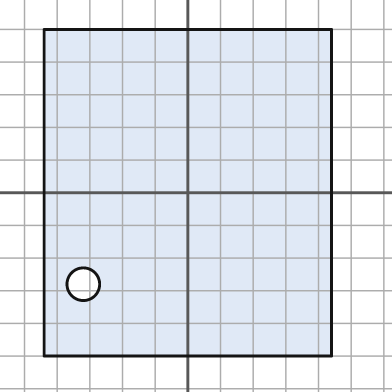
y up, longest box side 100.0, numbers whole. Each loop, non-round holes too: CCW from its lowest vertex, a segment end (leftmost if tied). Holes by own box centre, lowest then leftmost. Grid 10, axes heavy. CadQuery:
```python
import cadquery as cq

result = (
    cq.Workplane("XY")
    .moveTo(-44.0, -50.0)
    .lineTo(44.0, -50.0)
    .lineTo(44.0, 50.0)
    .lineTo(-44.0, 50.0)
    .close()
    .moveTo(-32.0, -28.0)
    .circle(5.0)
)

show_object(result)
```